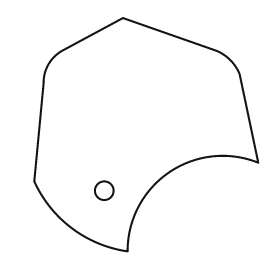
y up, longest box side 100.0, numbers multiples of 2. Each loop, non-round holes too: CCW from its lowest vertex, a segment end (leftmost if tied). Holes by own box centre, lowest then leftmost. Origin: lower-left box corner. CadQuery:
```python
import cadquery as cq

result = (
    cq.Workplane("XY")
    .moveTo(40.0, 0.0)
    .threePointArc((58.0, 34.0), (96.0, 38.0))
    .lineTo(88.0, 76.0)
    .threePointArc((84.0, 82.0), (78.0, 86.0))
    .lineTo(38.0, 100.0)
    .lineTo(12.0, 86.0)
    .threePointArc((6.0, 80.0), (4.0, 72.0))
    .lineTo(0.0, 30.0)
    .threePointArc((16.0, 10.0), (40.0, 0.0))
    .close()
    .moveTo(30.0, 26.0)
    .circle(4.0)
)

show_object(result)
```